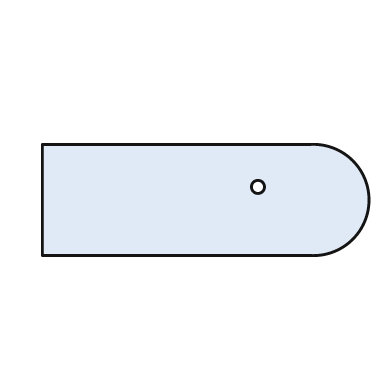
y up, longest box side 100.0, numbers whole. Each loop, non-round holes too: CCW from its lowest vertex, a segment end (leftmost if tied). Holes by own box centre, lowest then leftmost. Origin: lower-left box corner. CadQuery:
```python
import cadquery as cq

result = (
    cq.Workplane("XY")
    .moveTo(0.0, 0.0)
    .lineTo(82.0, 0.0)
    .threePointArc((100.0, 17.0), (82.0, 34.0))
    .lineTo(0.0, 34.0)
    .close()
    .moveTo(66.0, 21.0)
    .circle(2.0)
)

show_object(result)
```